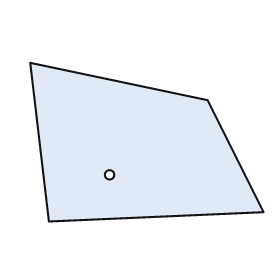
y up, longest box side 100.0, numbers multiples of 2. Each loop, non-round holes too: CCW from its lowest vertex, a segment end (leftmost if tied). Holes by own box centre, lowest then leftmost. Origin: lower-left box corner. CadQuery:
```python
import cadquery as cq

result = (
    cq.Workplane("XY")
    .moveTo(8.0, 0.0)
    .lineTo(100.0, 4.0)
    .lineTo(76.0, 52.0)
    .lineTo(0.0, 68.0)
    .close()
    .moveTo(34.0, 20.0)
    .circle(2.0)
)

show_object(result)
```